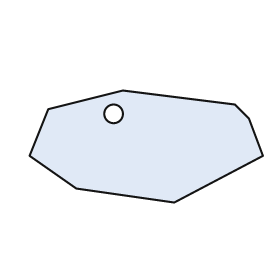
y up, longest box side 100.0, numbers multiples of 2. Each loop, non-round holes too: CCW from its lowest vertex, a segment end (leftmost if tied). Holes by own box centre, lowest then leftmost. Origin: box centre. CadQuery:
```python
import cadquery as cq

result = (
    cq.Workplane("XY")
    .moveTo(12.0, -24.0)
    .lineTo(50.0, -4.0)
    .lineTo(44.0, 12.0)
    .lineTo(38.0, 18.0)
    .lineTo(-10.0, 24.0)
    .lineTo(-42.0, 16.0)
    .lineTo(-50.0, -4.0)
    .lineTo(-30.0, -18.0)
    .close()
    .moveTo(-14.0, 14.0)
    .circle(4.0)
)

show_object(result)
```